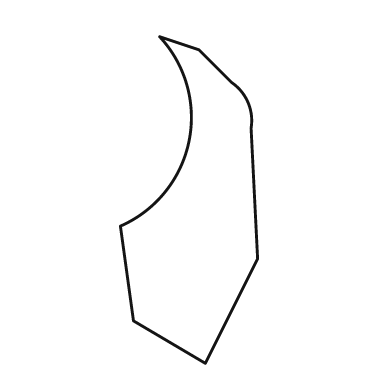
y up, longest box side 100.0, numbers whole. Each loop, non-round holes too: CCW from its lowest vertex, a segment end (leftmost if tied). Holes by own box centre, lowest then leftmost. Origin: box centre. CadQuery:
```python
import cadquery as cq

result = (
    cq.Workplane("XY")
    .moveTo(5.0, -50.0)
    .lineTo(21.0, -18.0)
    .lineTo(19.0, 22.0)
    .threePointArc((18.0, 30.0), (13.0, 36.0))
    .lineTo(3.0, 46.0)
    .lineTo(-9.0, 50.0)
    .threePointArc((0.0, 18.0), (-21.0, -8.0))
    .lineTo(-17.0, -37.0)
    .close()
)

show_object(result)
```